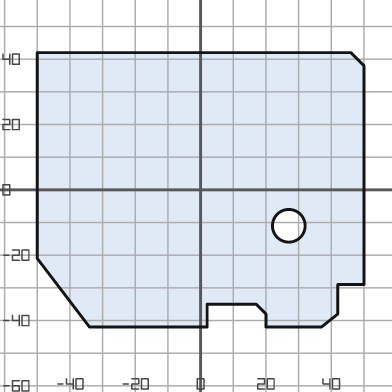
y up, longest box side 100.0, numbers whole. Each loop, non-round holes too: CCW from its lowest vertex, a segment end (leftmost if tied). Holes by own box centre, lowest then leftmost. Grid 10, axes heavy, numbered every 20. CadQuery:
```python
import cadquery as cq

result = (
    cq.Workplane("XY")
    .moveTo(-34.0, -42.0)
    .lineTo(2.0, -42.0)
    .lineTo(2.0, -35.0)
    .lineTo(17.0, -35.0)
    .lineTo(20.0, -38.0)
    .lineTo(20.0, -42.0)
    .lineTo(37.0, -42.0)
    .lineTo(42.0, -38.0)
    .lineTo(42.0, -29.0)
    .lineTo(50.0, -29.0)
    .lineTo(50.0, 38.0)
    .lineTo(46.0, 42.0)
    .lineTo(-50.0, 42.0)
    .lineTo(-50.0, -21.0)
    .close()
    .moveTo(27.0, -11.0)
    .circle(5.0)
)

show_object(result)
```